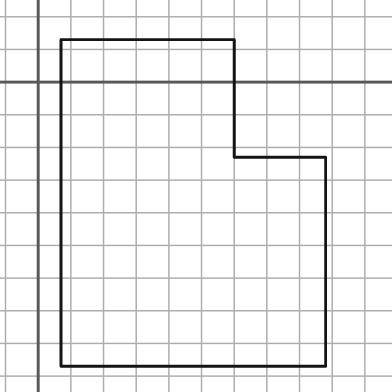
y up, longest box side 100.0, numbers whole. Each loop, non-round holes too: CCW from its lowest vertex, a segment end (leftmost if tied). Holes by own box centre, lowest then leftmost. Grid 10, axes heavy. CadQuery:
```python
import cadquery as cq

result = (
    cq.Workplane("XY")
    .moveTo(7.0, -87.0)
    .lineTo(88.0, -87.0)
    .lineTo(88.0, -23.0)
    .lineTo(60.0, -23.0)
    .lineTo(60.0, 13.0)
    .lineTo(7.0, 13.0)
    .close()
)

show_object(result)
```